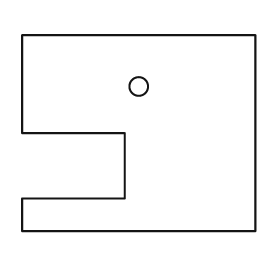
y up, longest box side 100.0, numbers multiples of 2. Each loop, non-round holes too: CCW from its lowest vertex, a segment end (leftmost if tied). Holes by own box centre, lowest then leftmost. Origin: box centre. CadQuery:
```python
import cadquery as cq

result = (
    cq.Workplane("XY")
    .moveTo(-50.0, -42.0)
    .lineTo(50.0, -42.0)
    .lineTo(50.0, 42.0)
    .lineTo(-50.0, 42.0)
    .lineTo(-50.0, 0.0)
    .lineTo(-6.0, 0.0)
    .lineTo(-6.0, -28.0)
    .lineTo(-50.0, -28.0)
    .close()
    .moveTo(0.0, 20.0)
    .circle(4.0)
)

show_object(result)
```